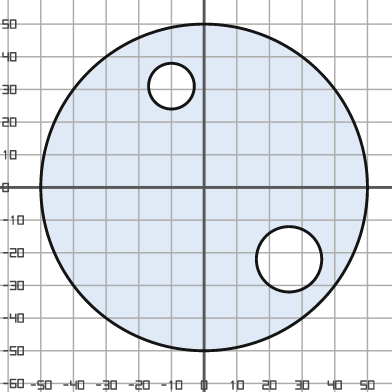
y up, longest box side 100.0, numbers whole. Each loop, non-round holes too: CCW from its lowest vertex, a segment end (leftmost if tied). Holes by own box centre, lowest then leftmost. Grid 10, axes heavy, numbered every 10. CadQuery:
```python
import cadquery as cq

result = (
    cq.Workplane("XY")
    .moveTo(0.0, 0.0)
    .circle(50.0)
    .moveTo(26.0, -22.0)
    .circle(10.0)
    .moveTo(-10.0, 31.0)
    .circle(7.0)
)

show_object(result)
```